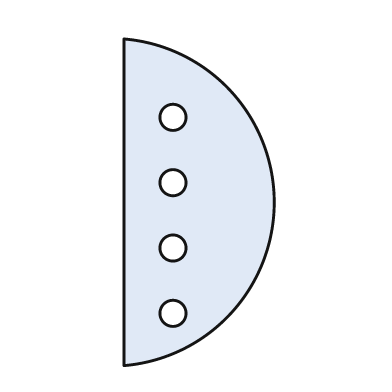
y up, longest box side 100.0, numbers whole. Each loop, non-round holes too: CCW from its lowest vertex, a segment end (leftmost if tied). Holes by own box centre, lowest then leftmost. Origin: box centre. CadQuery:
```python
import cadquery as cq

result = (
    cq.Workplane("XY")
    .moveTo(-23.0, -50.0)
    .threePointArc((23.0, 0.0), (-23.0, 50.0))
    .close()
    .moveTo(-8.0, -34.0)
    .circle(4.0)
    .moveTo(-8.0, -14.0)
    .circle(4.0)
    .moveTo(-8.0, 6.0)
    .circle(4.0)
    .moveTo(-8.0, 26.0)
    .circle(4.0)
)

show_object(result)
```